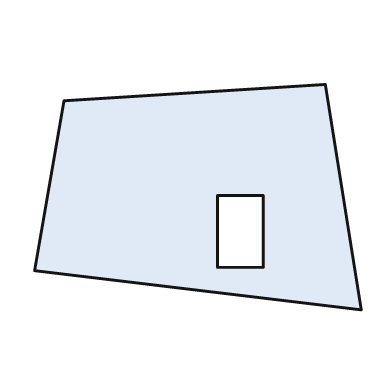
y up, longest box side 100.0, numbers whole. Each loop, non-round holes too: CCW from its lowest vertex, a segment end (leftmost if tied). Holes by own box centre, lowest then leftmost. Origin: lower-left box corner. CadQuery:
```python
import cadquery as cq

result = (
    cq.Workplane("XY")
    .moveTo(100.0, 0.0)
    .lineTo(89.0, 69.0)
    .lineTo(9.0, 64.0)
    .lineTo(0.0, 12.0)
    .close()
    .moveTo(56.0, 13.0)
    .lineTo(70.0, 13.0)
    .lineTo(70.0, 35.0)
    .lineTo(56.0, 35.0)
    .close()
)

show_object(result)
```